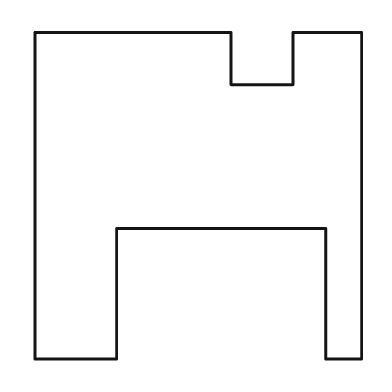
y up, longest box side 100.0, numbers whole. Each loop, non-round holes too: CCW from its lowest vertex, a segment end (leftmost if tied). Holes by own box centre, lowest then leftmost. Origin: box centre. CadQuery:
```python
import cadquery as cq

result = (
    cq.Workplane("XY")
    .moveTo(-50.0, -50.0)
    .lineTo(-25.0, -50.0)
    .lineTo(-25.0, -10.0)
    .lineTo(39.0, -10.0)
    .lineTo(39.0, -50.0)
    .lineTo(50.0, -50.0)
    .lineTo(50.0, 50.0)
    .lineTo(29.0, 50.0)
    .lineTo(29.0, 34.0)
    .lineTo(10.0, 34.0)
    .lineTo(10.0, 50.0)
    .lineTo(-50.0, 50.0)
    .close()
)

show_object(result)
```